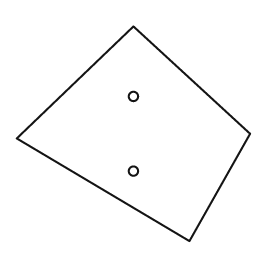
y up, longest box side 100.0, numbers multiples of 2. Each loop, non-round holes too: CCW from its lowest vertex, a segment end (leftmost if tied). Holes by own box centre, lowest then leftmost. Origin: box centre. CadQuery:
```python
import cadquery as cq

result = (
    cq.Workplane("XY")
    .moveTo(24.0, -46.0)
    .lineTo(50.0, 0.0)
    .lineTo(0.0, 46.0)
    .lineTo(-50.0, -2.0)
    .close()
    .moveTo(0.0, -16.0)
    .circle(2.0)
    .moveTo(0.0, 16.0)
    .circle(2.0)
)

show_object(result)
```